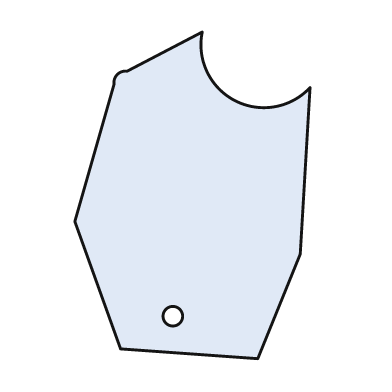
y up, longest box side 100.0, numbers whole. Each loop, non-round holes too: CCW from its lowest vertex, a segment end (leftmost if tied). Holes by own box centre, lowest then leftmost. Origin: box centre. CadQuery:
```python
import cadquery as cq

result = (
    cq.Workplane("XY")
    .moveTo(20.0, -50.0)
    .lineTo(33.0, -18.0)
    .lineTo(36.0, 33.0)
    .threePointArc((13.0, 29.0), (3.0, 50.0))
    .lineTo(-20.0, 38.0)
    .threePointArc((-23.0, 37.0), (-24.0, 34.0))
    .lineTo(-36.0, -8.0)
    .lineTo(-22.0, -47.0)
    .close()
    .moveTo(-6.0, -37.0)
    .circle(3.0)
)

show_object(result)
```